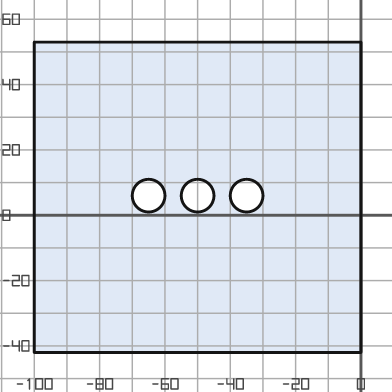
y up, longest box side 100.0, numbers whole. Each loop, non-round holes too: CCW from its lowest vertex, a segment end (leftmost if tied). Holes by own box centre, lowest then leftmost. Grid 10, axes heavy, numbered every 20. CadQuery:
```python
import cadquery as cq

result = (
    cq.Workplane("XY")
    .moveTo(-100.0, -42.0)
    .lineTo(0.0, -42.0)
    .lineTo(0.0, 53.0)
    .lineTo(-100.0, 53.0)
    .close()
    .moveTo(-65.0, 6.0)
    .circle(5.0)
    .moveTo(-50.0, 6.0)
    .circle(5.0)
    .moveTo(-35.0, 6.0)
    .circle(5.0)
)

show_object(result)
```